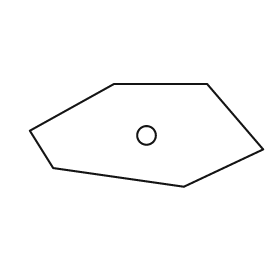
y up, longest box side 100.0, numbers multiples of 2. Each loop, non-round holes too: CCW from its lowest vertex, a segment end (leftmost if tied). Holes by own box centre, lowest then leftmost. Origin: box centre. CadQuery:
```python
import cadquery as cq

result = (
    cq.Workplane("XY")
    .moveTo(16.0, -22.0)
    .lineTo(50.0, -6.0)
    .lineTo(26.0, 22.0)
    .lineTo(-14.0, 22.0)
    .lineTo(-50.0, 2.0)
    .lineTo(-40.0, -14.0)
    .close()
    .moveTo(0.0, 0.0)
    .circle(4.0)
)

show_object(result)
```